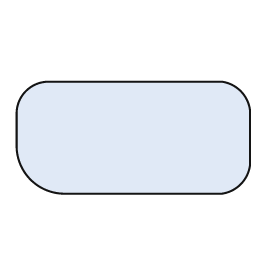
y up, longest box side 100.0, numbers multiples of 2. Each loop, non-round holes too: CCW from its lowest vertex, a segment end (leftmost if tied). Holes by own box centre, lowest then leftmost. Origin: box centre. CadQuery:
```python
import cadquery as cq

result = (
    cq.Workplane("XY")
    .moveTo(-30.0, -24.0)
    .lineTo(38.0, -24.0)
    .threePointArc((46.0, -20.0), (50.0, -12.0))
    .lineTo(50.0, 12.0)
    .threePointArc((46.0, 20.0), (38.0, 24.0))
    .lineTo(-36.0, 24.0)
    .threePointArc((-46.0, 20.0), (-50.0, 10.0))
    .lineTo(-50.0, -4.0)
    .threePointArc((-44.0, -18.0), (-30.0, -24.0))
    .close()
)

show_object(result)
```